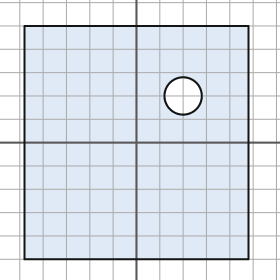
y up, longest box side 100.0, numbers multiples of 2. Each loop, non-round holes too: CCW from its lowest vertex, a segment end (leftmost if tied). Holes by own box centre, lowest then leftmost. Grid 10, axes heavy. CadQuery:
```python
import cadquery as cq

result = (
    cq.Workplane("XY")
    .moveTo(-48.0, -50.0)
    .lineTo(48.0, -50.0)
    .lineTo(48.0, 50.0)
    .lineTo(-48.0, 50.0)
    .close()
    .moveTo(20.0, 20.0)
    .circle(8.0)
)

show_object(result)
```